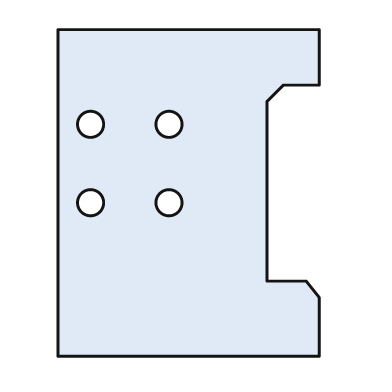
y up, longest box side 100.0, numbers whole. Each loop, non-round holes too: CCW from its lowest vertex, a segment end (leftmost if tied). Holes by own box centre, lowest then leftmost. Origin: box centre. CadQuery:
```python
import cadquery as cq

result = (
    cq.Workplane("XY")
    .moveTo(-40.0, -50.0)
    .lineTo(40.0, -50.0)
    .lineTo(40.0, -32.0)
    .lineTo(36.0, -27.0)
    .lineTo(24.0, -27.0)
    .lineTo(24.0, 28.0)
    .lineTo(29.0, 33.0)
    .lineTo(40.0, 33.0)
    .lineTo(40.0, 50.0)
    .lineTo(-40.0, 50.0)
    .close()
    .moveTo(-30.0, -3.0)
    .circle(4.0)
    .moveTo(-6.0, -3.0)
    .circle(4.0)
    .moveTo(-30.0, 21.0)
    .circle(4.0)
    .moveTo(-6.0, 21.0)
    .circle(4.0)
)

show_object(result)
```